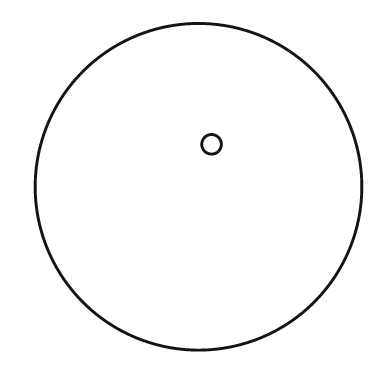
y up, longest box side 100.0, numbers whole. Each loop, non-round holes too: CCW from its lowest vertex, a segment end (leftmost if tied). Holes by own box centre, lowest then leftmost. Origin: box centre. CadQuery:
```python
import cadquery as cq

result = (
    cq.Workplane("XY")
    .moveTo(0.0, 0.0)
    .circle(50.0)
    .moveTo(4.0, 13.0)
    .circle(3.0)
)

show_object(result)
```